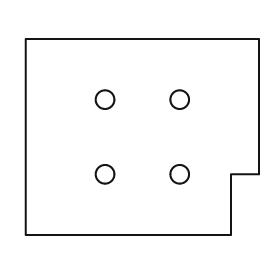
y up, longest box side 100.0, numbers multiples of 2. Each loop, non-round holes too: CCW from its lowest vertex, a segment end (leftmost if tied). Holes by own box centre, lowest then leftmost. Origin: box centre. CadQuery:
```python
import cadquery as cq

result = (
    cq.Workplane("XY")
    .moveTo(-50.0, -42.0)
    .lineTo(38.0, -42.0)
    .lineTo(38.0, -16.0)
    .lineTo(50.0, -16.0)
    .lineTo(50.0, 42.0)
    .lineTo(-50.0, 42.0)
    .close()
    .moveTo(-16.0, -16.0)
    .circle(4.0)
    .moveTo(16.0, -16.0)
    .circle(4.0)
    .moveTo(-16.0, 16.0)
    .circle(4.0)
    .moveTo(16.0, 16.0)
    .circle(4.0)
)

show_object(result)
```